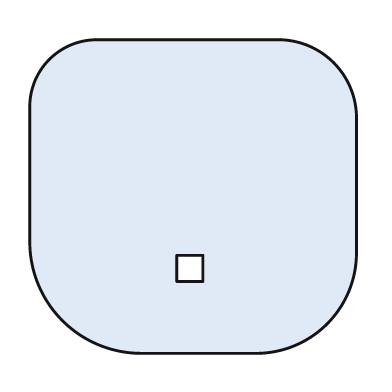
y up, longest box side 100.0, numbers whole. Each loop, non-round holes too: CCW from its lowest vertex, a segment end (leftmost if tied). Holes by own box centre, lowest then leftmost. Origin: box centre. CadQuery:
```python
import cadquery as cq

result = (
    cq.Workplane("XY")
    .moveTo(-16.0, -48.0)
    .lineTo(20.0, -48.0)
    .threePointArc((41.0, -39.0), (50.0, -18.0))
    .lineTo(50.0, 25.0)
    .threePointArc((43.0, 41.0), (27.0, 48.0))
    .lineTo(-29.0, 48.0)
    .threePointArc((-44.0, 42.0), (-50.0, 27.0))
    .lineTo(-50.0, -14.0)
    .threePointArc((-40.0, -38.0), (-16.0, -48.0))
    .close()
    .moveTo(-5.0, -26.0)
    .lineTo(3.0, -26.0)
    .lineTo(3.0, -18.0)
    .lineTo(-5.0, -18.0)
    .close()
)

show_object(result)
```